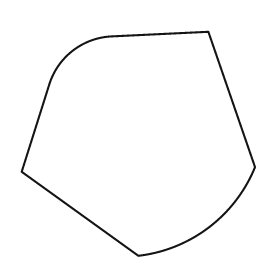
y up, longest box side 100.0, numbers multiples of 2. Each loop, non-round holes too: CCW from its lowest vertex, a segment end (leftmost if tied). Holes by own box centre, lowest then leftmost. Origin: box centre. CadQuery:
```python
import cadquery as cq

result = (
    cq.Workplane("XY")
    .moveTo(0.0, -48.0)
    .threePointArc((30.0, -36.0), (50.0, -10.0))
    .lineTo(30.0, 48.0)
    .lineTo(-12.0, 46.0)
    .threePointArc((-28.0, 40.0), (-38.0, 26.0))
    .lineTo(-50.0, -12.0)
    .close()
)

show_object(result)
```